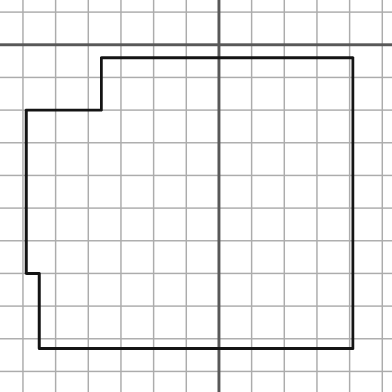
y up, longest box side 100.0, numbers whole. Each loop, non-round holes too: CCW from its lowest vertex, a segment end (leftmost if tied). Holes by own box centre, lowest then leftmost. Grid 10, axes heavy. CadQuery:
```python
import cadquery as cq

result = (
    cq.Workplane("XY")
    .moveTo(-55.0, -93.0)
    .lineTo(41.0, -93.0)
    .lineTo(41.0, -4.0)
    .lineTo(-36.0, -4.0)
    .lineTo(-36.0, -20.0)
    .lineTo(-59.0, -20.0)
    .lineTo(-59.0, -70.0)
    .lineTo(-55.0, -70.0)
    .close()
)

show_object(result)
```